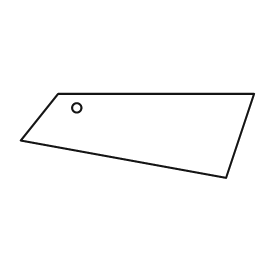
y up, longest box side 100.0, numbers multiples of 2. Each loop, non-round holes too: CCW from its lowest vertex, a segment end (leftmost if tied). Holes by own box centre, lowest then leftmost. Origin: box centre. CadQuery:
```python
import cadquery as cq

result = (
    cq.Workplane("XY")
    .moveTo(38.0, -18.0)
    .lineTo(50.0, 18.0)
    .lineTo(-34.0, 18.0)
    .lineTo(-50.0, -2.0)
    .close()
    .moveTo(-26.0, 12.0)
    .circle(2.0)
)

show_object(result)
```